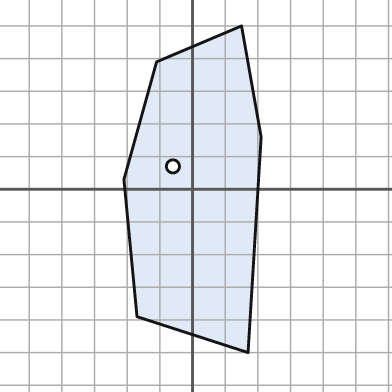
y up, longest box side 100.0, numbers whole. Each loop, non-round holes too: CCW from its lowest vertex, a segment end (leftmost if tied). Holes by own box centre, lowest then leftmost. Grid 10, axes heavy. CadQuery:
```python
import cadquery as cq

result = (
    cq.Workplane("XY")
    .moveTo(17.0, -50.0)
    .lineTo(21.0, 16.0)
    .lineTo(15.0, 50.0)
    .lineTo(-11.0, 39.0)
    .lineTo(-21.0, 3.0)
    .lineTo(-17.0, -39.0)
    .close()
    .moveTo(-6.0, 7.0)
    .circle(2.0)
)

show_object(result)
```